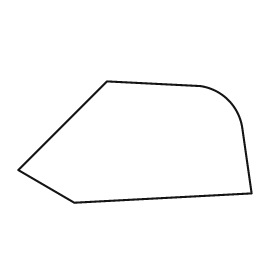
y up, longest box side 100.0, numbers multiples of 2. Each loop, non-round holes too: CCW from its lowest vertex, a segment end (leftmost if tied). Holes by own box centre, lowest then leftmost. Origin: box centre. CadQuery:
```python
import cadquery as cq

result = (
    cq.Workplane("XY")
    .moveTo(-26.0, -26.0)
    .lineTo(50.0, -22.0)
    .lineTo(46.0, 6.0)
    .threePointArc((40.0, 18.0), (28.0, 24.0))
    .lineTo(-12.0, 26.0)
    .lineTo(-50.0, -12.0)
    .close()
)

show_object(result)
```